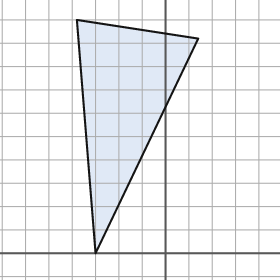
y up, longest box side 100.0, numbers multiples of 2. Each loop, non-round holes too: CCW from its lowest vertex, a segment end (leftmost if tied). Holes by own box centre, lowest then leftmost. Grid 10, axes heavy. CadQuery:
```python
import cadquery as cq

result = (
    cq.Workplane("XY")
    .moveTo(-30.0, 0.0)
    .lineTo(14.0, 92.0)
    .lineTo(-38.0, 100.0)
    .close()
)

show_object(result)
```